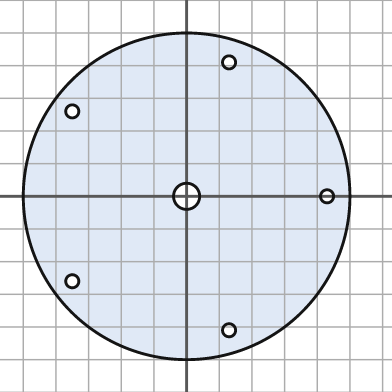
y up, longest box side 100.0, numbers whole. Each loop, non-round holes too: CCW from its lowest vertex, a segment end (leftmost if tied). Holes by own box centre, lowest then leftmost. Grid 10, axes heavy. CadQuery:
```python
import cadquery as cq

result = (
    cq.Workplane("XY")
    .moveTo(0.0, 0.0)
    .circle(50.0)
    .moveTo(13.0, -41.0)
    .circle(2.0)
    .moveTo(-35.0, -26.0)
    .circle(2.0)
    .moveTo(0.0, 0.0)
    .circle(4.0)
    .moveTo(43.0, 0.0)
    .circle(2.0)
    .moveTo(-35.0, 26.0)
    .circle(2.0)
    .moveTo(13.0, 41.0)
    .circle(2.0)
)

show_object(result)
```